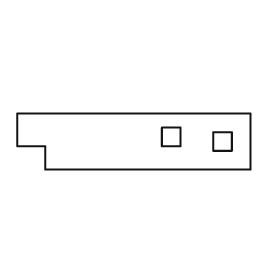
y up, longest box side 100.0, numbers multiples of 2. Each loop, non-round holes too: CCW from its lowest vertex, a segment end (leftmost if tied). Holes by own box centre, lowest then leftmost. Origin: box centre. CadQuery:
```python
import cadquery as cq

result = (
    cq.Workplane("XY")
    .moveTo(-38.0, -12.0)
    .lineTo(50.0, -12.0)
    .lineTo(50.0, 12.0)
    .lineTo(-50.0, 12.0)
    .lineTo(-50.0, -2.0)
    .lineTo(-38.0, -2.0)
    .close()
    .moveTo(34.0, -4.0)
    .lineTo(42.0, -4.0)
    .lineTo(42.0, 4.0)
    .lineTo(34.0, 4.0)
    .close()
    .moveTo(12.0, -2.0)
    .lineTo(20.0, -2.0)
    .lineTo(20.0, 6.0)
    .lineTo(12.0, 6.0)
    .close()
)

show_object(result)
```